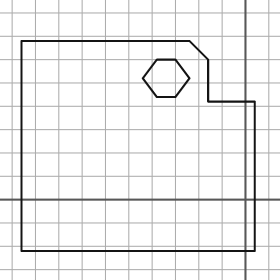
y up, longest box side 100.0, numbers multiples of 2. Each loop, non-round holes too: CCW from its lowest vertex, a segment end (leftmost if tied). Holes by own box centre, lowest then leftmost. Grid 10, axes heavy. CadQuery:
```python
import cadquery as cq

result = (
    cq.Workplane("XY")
    .moveTo(-96.0, -22.0)
    .lineTo(4.0, -22.0)
    .lineTo(4.0, 42.0)
    .lineTo(-16.0, 42.0)
    .lineTo(-16.0, 60.0)
    .lineTo(-24.0, 68.0)
    .lineTo(-96.0, 68.0)
    .close()
    .moveTo(-38.0, 44.0)
    .lineTo(-30.0, 44.0)
    .lineTo(-24.0, 52.0)
    .lineTo(-30.0, 60.0)
    .lineTo(-38.0, 60.0)
    .lineTo(-44.0, 52.0)
    .close()
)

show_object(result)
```